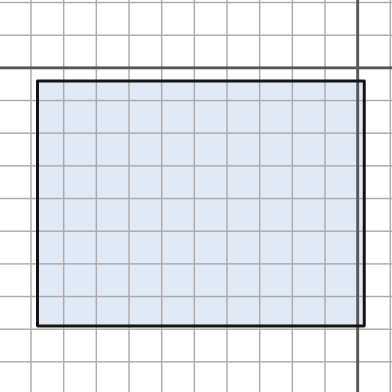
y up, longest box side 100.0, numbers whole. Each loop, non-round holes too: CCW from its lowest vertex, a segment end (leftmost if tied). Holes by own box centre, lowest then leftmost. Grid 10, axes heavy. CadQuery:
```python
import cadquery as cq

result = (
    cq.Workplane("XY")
    .moveTo(-98.0, -79.0)
    .lineTo(2.0, -79.0)
    .lineTo(2.0, -4.0)
    .lineTo(-98.0, -4.0)
    .close()
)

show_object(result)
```